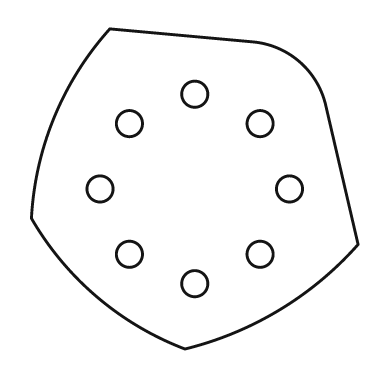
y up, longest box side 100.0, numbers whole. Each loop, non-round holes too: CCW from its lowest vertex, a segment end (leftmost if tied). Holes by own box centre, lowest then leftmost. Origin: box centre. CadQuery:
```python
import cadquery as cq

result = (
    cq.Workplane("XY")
    .moveTo(-3.0, -49.0)
    .threePointArc((26.0, -37.0), (50.0, -17.0))
    .lineTo(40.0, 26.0)
    .threePointArc((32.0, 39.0), (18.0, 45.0))
    .lineTo(-26.0, 49.0)
    .threePointArc((-43.0, 22.0), (-50.0, -9.0))
    .threePointArc((-30.0, -33.0), (-3.0, -49.0))
    .close()
    .moveTo(0.0, -29.0)
    .circle(4.0)
    .moveTo(-20.0, -20.0)
    .circle(4.0)
    .moveTo(20.0, -20.0)
    .circle(4.0)
    .moveTo(-29.0, 0.0)
    .circle(4.0)
    .moveTo(29.0, 0.0)
    .circle(4.0)
    .moveTo(-20.0, 20.0)
    .circle(4.0)
    .moveTo(20.0, 20.0)
    .circle(4.0)
    .moveTo(0.0, 29.0)
    .circle(4.0)
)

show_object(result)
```